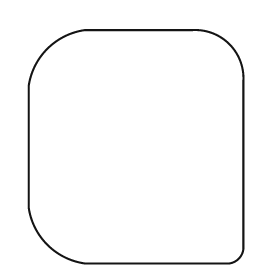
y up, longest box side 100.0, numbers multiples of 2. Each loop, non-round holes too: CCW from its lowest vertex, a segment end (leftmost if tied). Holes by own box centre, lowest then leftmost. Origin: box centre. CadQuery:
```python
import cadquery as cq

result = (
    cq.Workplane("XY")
    .moveTo(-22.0, -50.0)
    .lineTo(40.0, -50.0)
    .threePointArc((44.0, -48.0), (46.0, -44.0))
    .lineTo(46.0, 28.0)
    .threePointArc((40.0, 44.0), (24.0, 50.0))
    .lineTo(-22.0, 50.0)
    .threePointArc((-38.0, 42.0), (-46.0, 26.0))
    .lineTo(-46.0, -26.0)
    .threePointArc((-38.0, -42.0), (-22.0, -50.0))
    .close()
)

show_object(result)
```